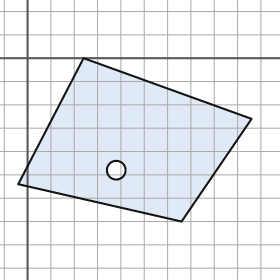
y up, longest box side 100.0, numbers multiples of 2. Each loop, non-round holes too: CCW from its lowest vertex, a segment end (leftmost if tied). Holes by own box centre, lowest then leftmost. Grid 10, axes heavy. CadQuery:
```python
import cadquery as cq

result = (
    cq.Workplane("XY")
    .moveTo(66.0, -70.0)
    .lineTo(96.0, -26.0)
    .lineTo(24.0, 0.0)
    .lineTo(-4.0, -54.0)
    .close()
    .moveTo(38.0, -48.0)
    .circle(4.0)
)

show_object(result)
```